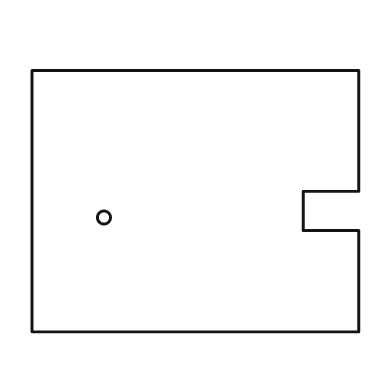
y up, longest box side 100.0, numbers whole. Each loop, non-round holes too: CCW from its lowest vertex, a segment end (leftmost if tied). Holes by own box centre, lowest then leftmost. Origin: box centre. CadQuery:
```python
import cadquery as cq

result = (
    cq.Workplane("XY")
    .moveTo(-50.0, -40.0)
    .lineTo(50.0, -40.0)
    .lineTo(50.0, -9.0)
    .lineTo(33.0, -9.0)
    .lineTo(33.0, 3.0)
    .lineTo(50.0, 3.0)
    .lineTo(50.0, 40.0)
    .lineTo(-50.0, 40.0)
    .close()
    .moveTo(-28.0, -5.0)
    .circle(2.0)
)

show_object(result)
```